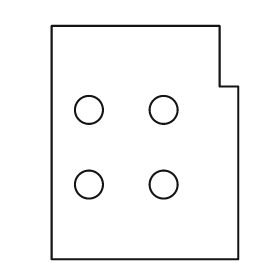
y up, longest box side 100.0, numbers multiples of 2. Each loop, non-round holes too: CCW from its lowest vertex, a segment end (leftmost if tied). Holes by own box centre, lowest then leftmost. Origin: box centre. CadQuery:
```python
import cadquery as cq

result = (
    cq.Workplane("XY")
    .moveTo(-40.0, -50.0)
    .lineTo(40.0, -50.0)
    .lineTo(40.0, 24.0)
    .lineTo(32.0, 24.0)
    .lineTo(32.0, 50.0)
    .lineTo(-40.0, 50.0)
    .close()
    .moveTo(-24.0, -18.0)
    .circle(6.0)
    .moveTo(8.0, -18.0)
    .circle(6.0)
    .moveTo(-24.0, 14.0)
    .circle(6.0)
    .moveTo(8.0, 14.0)
    .circle(6.0)
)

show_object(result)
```